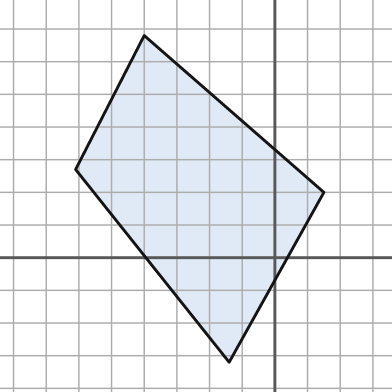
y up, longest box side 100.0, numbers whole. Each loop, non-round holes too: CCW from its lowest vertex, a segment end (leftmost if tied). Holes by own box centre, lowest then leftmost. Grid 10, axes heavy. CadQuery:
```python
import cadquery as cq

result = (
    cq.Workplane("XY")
    .moveTo(-14.0, -32.0)
    .lineTo(15.0, 20.0)
    .lineTo(-40.0, 68.0)
    .lineTo(-61.0, 27.0)
    .close()
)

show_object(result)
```